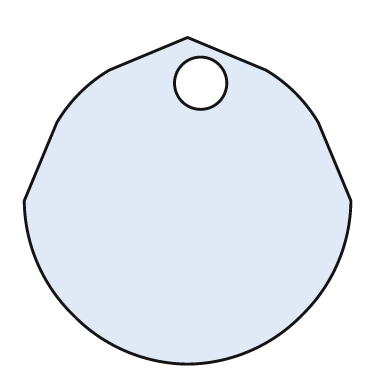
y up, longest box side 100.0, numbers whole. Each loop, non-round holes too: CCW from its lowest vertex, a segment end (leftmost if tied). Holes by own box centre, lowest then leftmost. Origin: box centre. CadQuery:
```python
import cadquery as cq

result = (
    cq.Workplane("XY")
    .moveTo(0.0, -50.0)
    .threePointArc((19.0, -46.0), (35.0, -35.0))
    .threePointArc((46.0, -19.0), (50.0, 0.0))
    .lineTo(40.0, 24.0)
    .threePointArc((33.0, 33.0), (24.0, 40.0))
    .lineTo(0.0, 50.0)
    .lineTo(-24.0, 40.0)
    .threePointArc((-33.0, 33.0), (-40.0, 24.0))
    .lineTo(-50.0, 0.0)
    .threePointArc((-46.0, -19.0), (-35.0, -35.0))
    .threePointArc((-19.0, -46.0), (0.0, -50.0))
    .close()
    .moveTo(4.0, 36.0)
    .circle(8.0)
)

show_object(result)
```